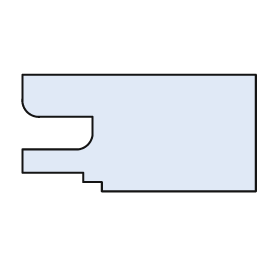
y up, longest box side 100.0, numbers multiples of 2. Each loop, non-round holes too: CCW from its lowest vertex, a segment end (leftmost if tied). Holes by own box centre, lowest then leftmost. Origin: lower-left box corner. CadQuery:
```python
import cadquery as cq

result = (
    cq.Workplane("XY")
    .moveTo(34.0, 0.0)
    .lineTo(100.0, 0.0)
    .lineTo(100.0, 50.0)
    .lineTo(0.0, 50.0)
    .lineTo(0.0, 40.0)
    .threePointArc((2.0, 34.0), (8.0, 32.0))
    .lineTo(30.0, 32.0)
    .lineTo(30.0, 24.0)
    .threePointArc((28.0, 20.0), (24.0, 18.0))
    .lineTo(0.0, 18.0)
    .lineTo(0.0, 8.0)
    .lineTo(26.0, 8.0)
    .lineTo(26.0, 4.0)
    .lineTo(34.0, 4.0)
    .close()
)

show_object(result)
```